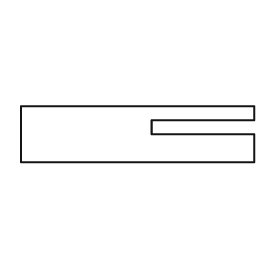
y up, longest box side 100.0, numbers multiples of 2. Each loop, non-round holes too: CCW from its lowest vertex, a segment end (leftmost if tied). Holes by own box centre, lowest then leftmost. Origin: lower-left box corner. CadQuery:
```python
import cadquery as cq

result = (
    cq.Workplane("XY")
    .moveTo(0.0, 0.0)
    .lineTo(100.0, 0.0)
    .lineTo(100.0, 12.0)
    .lineTo(56.0, 12.0)
    .lineTo(56.0, 18.0)
    .lineTo(100.0, 18.0)
    .lineTo(100.0, 24.0)
    .lineTo(0.0, 24.0)
    .close()
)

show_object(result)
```